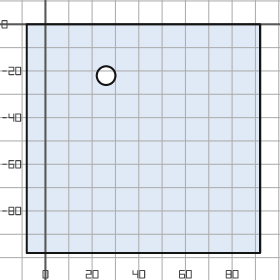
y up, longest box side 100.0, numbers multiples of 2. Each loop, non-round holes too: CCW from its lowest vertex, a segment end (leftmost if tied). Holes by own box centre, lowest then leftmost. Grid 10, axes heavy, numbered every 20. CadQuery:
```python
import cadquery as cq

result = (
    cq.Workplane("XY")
    .moveTo(-8.0, -98.0)
    .lineTo(92.0, -98.0)
    .lineTo(92.0, 0.0)
    .lineTo(-8.0, 0.0)
    .close()
    .moveTo(26.0, -22.0)
    .circle(4.0)
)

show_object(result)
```